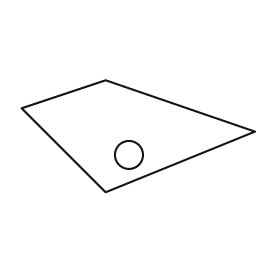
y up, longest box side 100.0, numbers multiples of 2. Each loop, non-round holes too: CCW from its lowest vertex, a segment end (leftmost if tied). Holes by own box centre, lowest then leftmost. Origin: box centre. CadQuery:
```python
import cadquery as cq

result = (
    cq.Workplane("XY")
    .moveTo(-14.0, -24.0)
    .lineTo(50.0, 2.0)
    .lineTo(-14.0, 24.0)
    .lineTo(-50.0, 12.0)
    .close()
    .moveTo(-4.0, -8.0)
    .circle(6.0)
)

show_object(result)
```